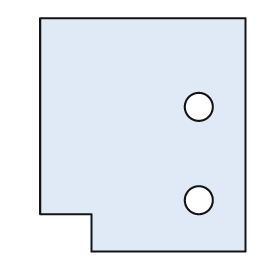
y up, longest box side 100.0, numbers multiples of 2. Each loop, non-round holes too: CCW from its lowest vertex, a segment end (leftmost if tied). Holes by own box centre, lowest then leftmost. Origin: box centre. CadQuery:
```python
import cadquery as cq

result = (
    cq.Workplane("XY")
    .moveTo(-22.0, -50.0)
    .lineTo(44.0, -50.0)
    .lineTo(44.0, 50.0)
    .lineTo(-44.0, 50.0)
    .lineTo(-44.0, -34.0)
    .lineTo(-22.0, -34.0)
    .close()
    .moveTo(24.0, -28.0)
    .circle(6.0)
    .moveTo(24.0, 12.0)
    .circle(6.0)
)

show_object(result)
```